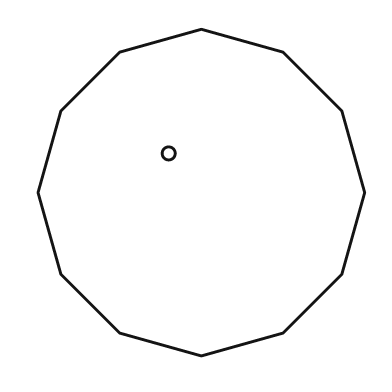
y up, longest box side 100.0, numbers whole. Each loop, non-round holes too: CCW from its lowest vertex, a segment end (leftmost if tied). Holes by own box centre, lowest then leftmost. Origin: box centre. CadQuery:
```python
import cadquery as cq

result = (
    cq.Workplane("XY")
    .moveTo(0.0, -50.0)
    .lineTo(25.0, -43.0)
    .lineTo(43.0, -25.0)
    .lineTo(50.0, 0.0)
    .lineTo(43.0, 25.0)
    .lineTo(25.0, 43.0)
    .lineTo(0.0, 50.0)
    .lineTo(-25.0, 43.0)
    .lineTo(-43.0, 25.0)
    .lineTo(-50.0, 0.0)
    .lineTo(-43.0, -25.0)
    .lineTo(-25.0, -43.0)
    .close()
    .moveTo(-10.0, 12.0)
    .circle(2.0)
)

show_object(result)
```